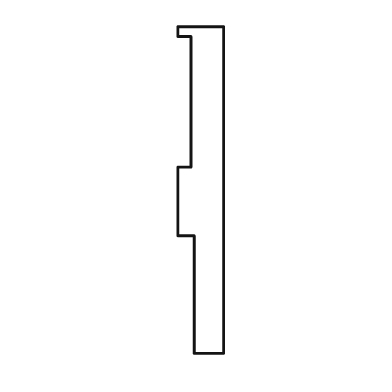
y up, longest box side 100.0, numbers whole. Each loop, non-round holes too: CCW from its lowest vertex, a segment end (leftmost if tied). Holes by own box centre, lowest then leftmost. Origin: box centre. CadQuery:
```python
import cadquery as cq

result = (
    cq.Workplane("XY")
    .moveTo(-2.0, -50.0)
    .lineTo(7.0, -50.0)
    .lineTo(7.0, 50.0)
    .lineTo(-7.0, 50.0)
    .lineTo(-7.0, 47.0)
    .lineTo(-3.0, 47.0)
    .lineTo(-3.0, 7.0)
    .lineTo(-7.0, 7.0)
    .lineTo(-7.0, -14.0)
    .lineTo(-2.0, -14.0)
    .close()
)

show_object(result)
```